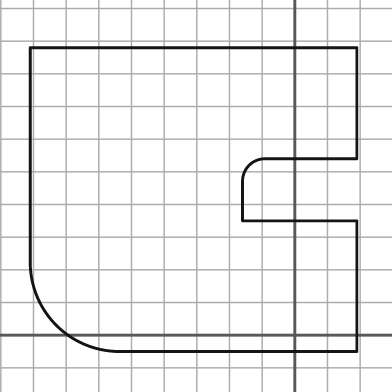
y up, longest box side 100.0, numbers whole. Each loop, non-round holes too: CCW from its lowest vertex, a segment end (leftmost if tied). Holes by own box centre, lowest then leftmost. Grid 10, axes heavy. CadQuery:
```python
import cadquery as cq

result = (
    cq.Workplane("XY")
    .moveTo(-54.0, -5.0)
    .lineTo(19.0, -5.0)
    .lineTo(19.0, 35.0)
    .lineTo(-16.0, 35.0)
    .lineTo(-16.0, 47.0)
    .threePointArc((-14.0, 52.0), (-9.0, 54.0))
    .lineTo(19.0, 54.0)
    .lineTo(19.0, 88.0)
    .lineTo(-81.0, 88.0)
    .lineTo(-81.0, 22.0)
    .threePointArc((-73.0, 3.0), (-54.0, -5.0))
    .close()
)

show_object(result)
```